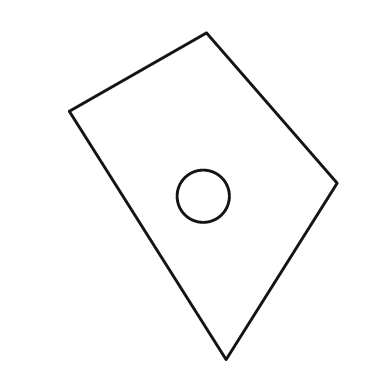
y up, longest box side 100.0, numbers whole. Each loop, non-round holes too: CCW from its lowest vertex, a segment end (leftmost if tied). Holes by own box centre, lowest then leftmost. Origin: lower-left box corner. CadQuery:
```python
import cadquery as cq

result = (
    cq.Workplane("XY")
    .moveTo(48.0, 0.0)
    .lineTo(82.0, 54.0)
    .lineTo(42.0, 100.0)
    .lineTo(0.0, 76.0)
    .close()
    .moveTo(41.0, 50.0)
    .circle(8.0)
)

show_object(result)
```